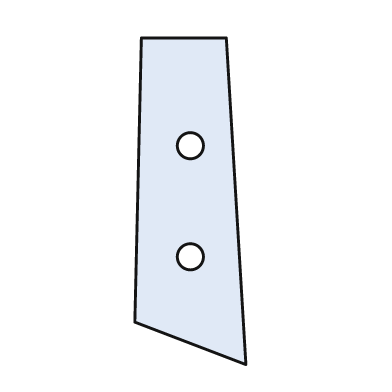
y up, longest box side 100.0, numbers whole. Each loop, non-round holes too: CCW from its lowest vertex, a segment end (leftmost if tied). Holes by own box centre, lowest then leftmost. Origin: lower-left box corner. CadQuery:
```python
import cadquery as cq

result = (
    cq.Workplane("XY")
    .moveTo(34.0, 0.0)
    .lineTo(28.0, 100.0)
    .lineTo(2.0, 100.0)
    .lineTo(0.0, 13.0)
    .close()
    .moveTo(17.0, 33.0)
    .circle(4.0)
    .moveTo(17.0, 67.0)
    .circle(4.0)
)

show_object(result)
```